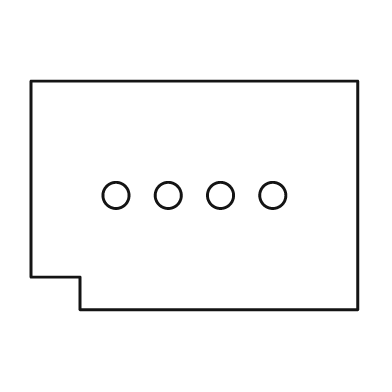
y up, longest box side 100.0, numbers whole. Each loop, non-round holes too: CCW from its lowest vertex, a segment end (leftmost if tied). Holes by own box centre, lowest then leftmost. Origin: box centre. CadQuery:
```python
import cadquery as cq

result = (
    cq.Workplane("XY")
    .moveTo(-35.0, -35.0)
    .lineTo(50.0, -35.0)
    .lineTo(50.0, 35.0)
    .lineTo(-50.0, 35.0)
    .lineTo(-50.0, -25.0)
    .lineTo(-35.0, -25.0)
    .close()
    .moveTo(-24.0, 0.0)
    .circle(4.0)
    .moveTo(-8.0, 0.0)
    .circle(4.0)
    .moveTo(8.0, 0.0)
    .circle(4.0)
    .moveTo(24.0, 0.0)
    .circle(4.0)
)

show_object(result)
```